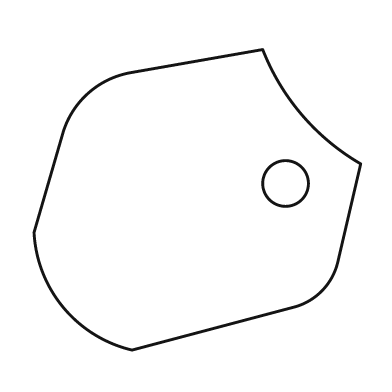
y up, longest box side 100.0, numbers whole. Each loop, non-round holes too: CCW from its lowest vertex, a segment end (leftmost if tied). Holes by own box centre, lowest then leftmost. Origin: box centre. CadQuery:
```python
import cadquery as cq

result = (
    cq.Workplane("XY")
    .moveTo(-20.0, -46.0)
    .lineTo(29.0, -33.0)
    .threePointArc((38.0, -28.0), (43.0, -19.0))
    .lineTo(50.0, 11.0)
    .threePointArc((32.0, 26.0), (20.0, 46.0))
    .lineTo(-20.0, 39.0)
    .threePointArc((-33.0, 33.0), (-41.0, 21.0))
    .lineTo(-50.0, -10.0)
    .threePointArc((-41.0, -33.0), (-20.0, -46.0))
    .close()
    .moveTo(27.0, 5.0)
    .circle(7.0)
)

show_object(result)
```